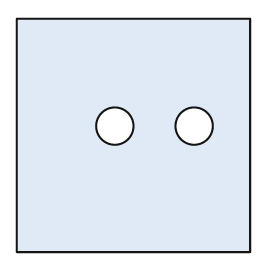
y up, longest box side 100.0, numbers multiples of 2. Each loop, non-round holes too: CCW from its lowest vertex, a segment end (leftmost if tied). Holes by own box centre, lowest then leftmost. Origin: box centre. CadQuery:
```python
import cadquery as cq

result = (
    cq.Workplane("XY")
    .moveTo(-50.0, -50.0)
    .lineTo(50.0, -50.0)
    .lineTo(50.0, 50.0)
    .lineTo(-50.0, 50.0)
    .close()
    .moveTo(-8.0, 4.0)
    .circle(8.0)
    .moveTo(26.0, 4.0)
    .circle(8.0)
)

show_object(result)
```